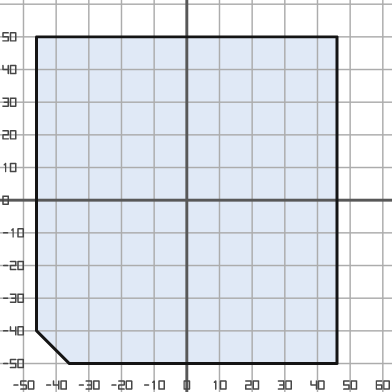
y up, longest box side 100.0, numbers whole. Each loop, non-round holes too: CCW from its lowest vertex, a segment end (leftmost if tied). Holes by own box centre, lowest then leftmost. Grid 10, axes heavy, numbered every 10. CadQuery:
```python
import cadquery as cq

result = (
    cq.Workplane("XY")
    .moveTo(-36.0, -50.0)
    .lineTo(46.0, -50.0)
    .lineTo(46.0, 50.0)
    .lineTo(-46.0, 50.0)
    .lineTo(-46.0, -40.0)
    .close()
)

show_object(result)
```